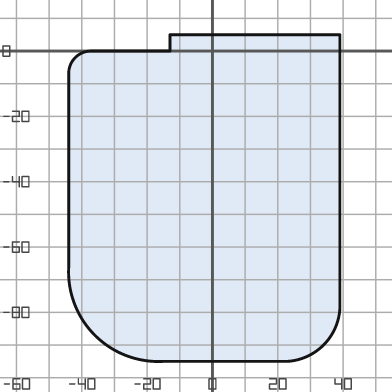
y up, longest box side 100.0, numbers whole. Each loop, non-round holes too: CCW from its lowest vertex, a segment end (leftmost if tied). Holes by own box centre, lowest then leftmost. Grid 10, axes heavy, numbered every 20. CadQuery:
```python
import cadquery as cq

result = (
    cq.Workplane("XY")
    .moveTo(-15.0, -95.0)
    .lineTo(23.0, -95.0)
    .threePointArc((34.0, -90.0), (39.0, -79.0))
    .lineTo(39.0, 5.0)
    .lineTo(-13.0, 5.0)
    .lineTo(-13.0, 0.0)
    .lineTo(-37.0, 0.0)
    .threePointArc((-42.0, -2.0), (-44.0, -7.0))
    .lineTo(-44.0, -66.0)
    .threePointArc((-36.0, -87.0), (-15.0, -95.0))
    .close()
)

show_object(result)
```